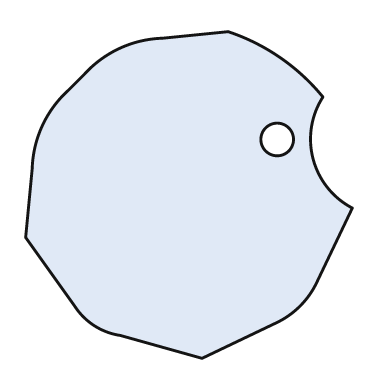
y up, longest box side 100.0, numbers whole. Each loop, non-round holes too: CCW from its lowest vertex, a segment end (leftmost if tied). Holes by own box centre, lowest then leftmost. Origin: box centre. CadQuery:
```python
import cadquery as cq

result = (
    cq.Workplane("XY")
    .moveTo(4.0, -50.0)
    .lineTo(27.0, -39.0)
    .threePointArc((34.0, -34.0), (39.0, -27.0))
    .lineTo(50.0, -4.0)
    .threePointArc((38.0, 11.0), (41.0, 30.0))
    .threePointArc((28.0, 42.0), (12.0, 50.0))
    .lineTo(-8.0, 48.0)
    .threePointArc((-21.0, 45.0), (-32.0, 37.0))
    .lineTo(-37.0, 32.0)
    .threePointArc((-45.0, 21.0), (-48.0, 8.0))
    .lineTo(-50.0, -13.0)
    .lineTo(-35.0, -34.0)
    .threePointArc((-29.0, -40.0), (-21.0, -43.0))
    .close()
    .moveTo(27.0, 17.0)
    .circle(5.0)
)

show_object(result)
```